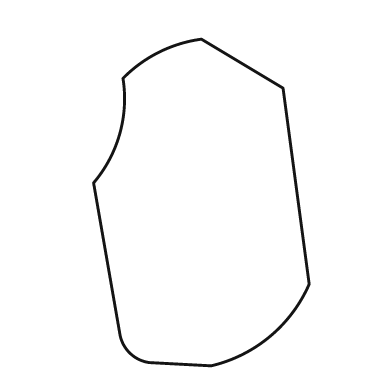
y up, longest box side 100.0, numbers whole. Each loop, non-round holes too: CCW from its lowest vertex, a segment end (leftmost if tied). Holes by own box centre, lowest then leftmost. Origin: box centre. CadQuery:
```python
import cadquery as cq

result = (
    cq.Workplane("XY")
    .moveTo(3.0, -50.0)
    .threePointArc((21.0, -41.0), (33.0, -25.0))
    .lineTo(25.0, 35.0)
    .lineTo(0.0, 50.0)
    .threePointArc((-13.0, 46.0), (-24.0, 38.0))
    .threePointArc((-25.0, 21.0), (-33.0, 6.0))
    .lineTo(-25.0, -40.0)
    .threePointArc((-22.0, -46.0), (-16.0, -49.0))
    .close()
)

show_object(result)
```